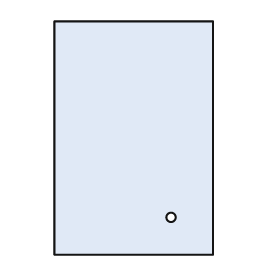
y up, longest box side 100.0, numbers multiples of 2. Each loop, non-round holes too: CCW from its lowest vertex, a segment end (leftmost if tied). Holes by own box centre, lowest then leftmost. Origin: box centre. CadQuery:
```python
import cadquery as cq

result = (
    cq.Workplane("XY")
    .moveTo(-34.0, -50.0)
    .lineTo(34.0, -50.0)
    .lineTo(34.0, 50.0)
    .lineTo(-34.0, 50.0)
    .close()
    .moveTo(16.0, -34.0)
    .circle(2.0)
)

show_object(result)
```